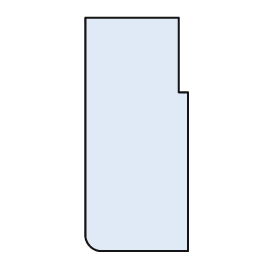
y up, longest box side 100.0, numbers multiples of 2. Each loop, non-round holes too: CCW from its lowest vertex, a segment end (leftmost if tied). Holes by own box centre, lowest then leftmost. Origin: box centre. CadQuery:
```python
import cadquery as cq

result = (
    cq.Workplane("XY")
    .moveTo(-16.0, -50.0)
    .lineTo(22.0, -50.0)
    .lineTo(22.0, 18.0)
    .lineTo(18.0, 18.0)
    .lineTo(18.0, 50.0)
    .lineTo(-22.0, 50.0)
    .lineTo(-22.0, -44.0)
    .threePointArc((-20.0, -48.0), (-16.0, -50.0))
    .close()
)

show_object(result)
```